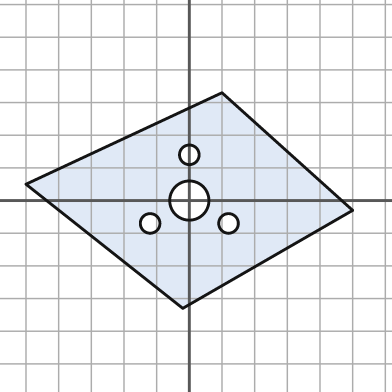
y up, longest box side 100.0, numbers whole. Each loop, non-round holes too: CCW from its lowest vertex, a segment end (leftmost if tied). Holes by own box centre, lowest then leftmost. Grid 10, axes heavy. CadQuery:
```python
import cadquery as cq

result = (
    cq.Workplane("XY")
    .moveTo(-2.0, -33.0)
    .lineTo(50.0, -3.0)
    .lineTo(10.0, 33.0)
    .lineTo(-50.0, 5.0)
    .close()
    .moveTo(-12.0, -7.0)
    .circle(3.0)
    .moveTo(12.0, -7.0)
    .circle(3.0)
    .moveTo(0.0, 0.0)
    .circle(6.0)
    .moveTo(0.0, 14.0)
    .circle(3.0)
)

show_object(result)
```